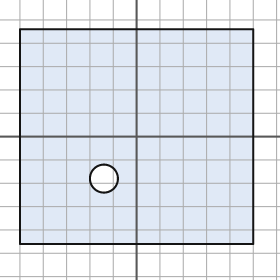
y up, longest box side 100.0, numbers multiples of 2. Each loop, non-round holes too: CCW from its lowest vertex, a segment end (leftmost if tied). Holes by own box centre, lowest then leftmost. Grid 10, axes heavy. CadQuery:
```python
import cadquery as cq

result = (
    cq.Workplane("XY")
    .moveTo(-50.0, -46.0)
    .lineTo(50.0, -46.0)
    .lineTo(50.0, 46.0)
    .lineTo(-50.0, 46.0)
    .close()
    .moveTo(-14.0, -18.0)
    .circle(6.0)
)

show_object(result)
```